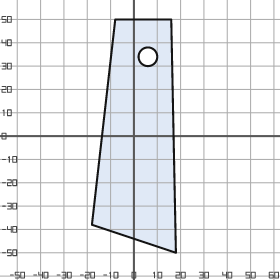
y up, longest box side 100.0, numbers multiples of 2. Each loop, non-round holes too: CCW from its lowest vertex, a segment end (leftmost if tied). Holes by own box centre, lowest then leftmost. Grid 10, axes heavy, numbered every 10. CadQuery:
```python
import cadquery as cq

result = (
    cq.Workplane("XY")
    .moveTo(18.0, -50.0)
    .lineTo(16.0, 50.0)
    .lineTo(-8.0, 50.0)
    .lineTo(-18.0, -38.0)
    .close()
    .moveTo(6.0, 34.0)
    .circle(4.0)
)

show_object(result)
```